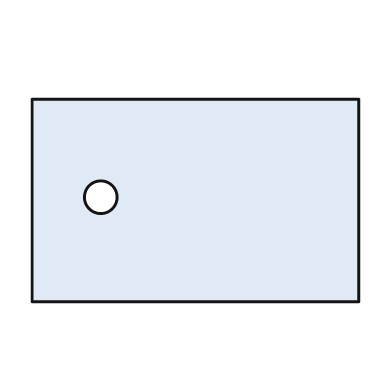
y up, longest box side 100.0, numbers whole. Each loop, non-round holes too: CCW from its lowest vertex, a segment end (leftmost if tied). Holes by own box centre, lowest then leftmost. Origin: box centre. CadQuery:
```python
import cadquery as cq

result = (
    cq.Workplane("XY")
    .moveTo(-50.0, -31.0)
    .lineTo(50.0, -31.0)
    .lineTo(50.0, 31.0)
    .lineTo(-50.0, 31.0)
    .close()
    .moveTo(-29.0, 1.0)
    .circle(5.0)
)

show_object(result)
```